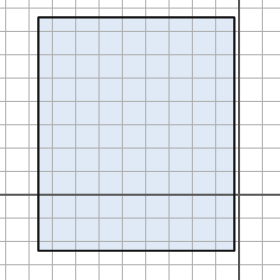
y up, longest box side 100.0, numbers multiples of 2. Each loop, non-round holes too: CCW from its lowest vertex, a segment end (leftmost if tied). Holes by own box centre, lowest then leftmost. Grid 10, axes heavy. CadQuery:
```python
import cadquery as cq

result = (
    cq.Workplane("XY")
    .moveTo(-86.0, -24.0)
    .lineTo(-2.0, -24.0)
    .lineTo(-2.0, 76.0)
    .lineTo(-86.0, 76.0)
    .close()
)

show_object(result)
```